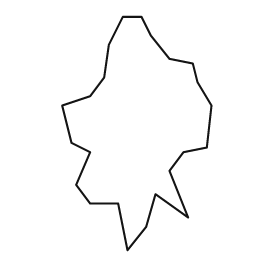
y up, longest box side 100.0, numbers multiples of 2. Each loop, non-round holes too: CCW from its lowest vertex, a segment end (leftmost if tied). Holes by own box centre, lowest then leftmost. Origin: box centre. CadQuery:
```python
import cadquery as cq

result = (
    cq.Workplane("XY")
    .moveTo(-4.0, -50.0)
    .lineTo(4.0, -40.0)
    .lineTo(8.0, -26.0)
    .lineTo(22.0, -36.0)
    .lineTo(14.0, -16.0)
    .lineTo(20.0, -8.0)
    .lineTo(30.0, -6.0)
    .lineTo(32.0, 12.0)
    .lineTo(26.0, 22.0)
    .lineTo(24.0, 30.0)
    .lineTo(14.0, 32.0)
    .lineTo(6.0, 42.0)
    .lineTo(2.0, 50.0)
    .lineTo(-6.0, 50.0)
    .lineTo(-12.0, 38.0)
    .lineTo(-14.0, 24.0)
    .lineTo(-20.0, 16.0)
    .lineTo(-32.0, 12.0)
    .lineTo(-28.0, -4.0)
    .lineTo(-20.0, -8.0)
    .lineTo(-26.0, -22.0)
    .lineTo(-20.0, -30.0)
    .lineTo(-8.0, -30.0)
    .close()
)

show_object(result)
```